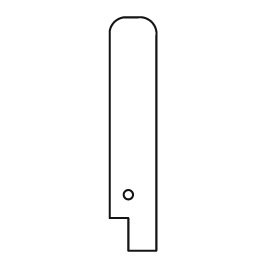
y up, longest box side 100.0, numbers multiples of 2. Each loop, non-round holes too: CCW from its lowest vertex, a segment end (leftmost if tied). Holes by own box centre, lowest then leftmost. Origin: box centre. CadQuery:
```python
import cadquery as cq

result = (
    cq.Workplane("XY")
    .moveTo(-2.0, -50.0)
    .lineTo(10.0, -50.0)
    .lineTo(10.0, 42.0)
    .threePointArc((8.0, 48.0), (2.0, 50.0))
    .lineTo(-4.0, 50.0)
    .threePointArc((-8.0, 48.0), (-10.0, 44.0))
    .lineTo(-10.0, -36.0)
    .lineTo(-2.0, -36.0)
    .close()
    .moveTo(-2.0, -26.0)
    .circle(2.0)
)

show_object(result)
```